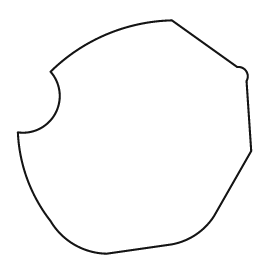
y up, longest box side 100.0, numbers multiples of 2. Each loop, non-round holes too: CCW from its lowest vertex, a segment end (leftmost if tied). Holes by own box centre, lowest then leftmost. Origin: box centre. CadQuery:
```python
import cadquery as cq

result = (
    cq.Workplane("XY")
    .moveTo(-12.0, -50.0)
    .lineTo(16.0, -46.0)
    .threePointArc((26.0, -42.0), (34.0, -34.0))
    .lineTo(50.0, -6.0)
    .lineTo(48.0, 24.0)
    .threePointArc((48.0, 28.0), (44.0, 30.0))
    .lineTo(16.0, 50.0)
    .threePointArc((-12.0, 44.0), (-36.0, 28.0))
    .threePointArc((-34.0, 10.0), (-50.0, 2.0))
    .threePointArc((-46.0, -18.0), (-36.0, -36.0))
    .threePointArc((-26.0, -46.0), (-12.0, -50.0))
    .close()
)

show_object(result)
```